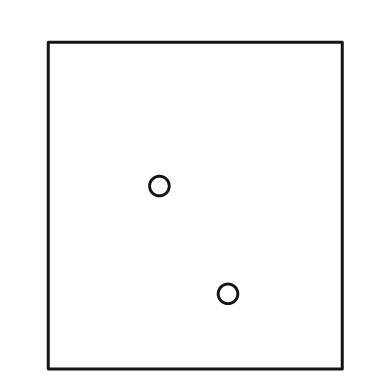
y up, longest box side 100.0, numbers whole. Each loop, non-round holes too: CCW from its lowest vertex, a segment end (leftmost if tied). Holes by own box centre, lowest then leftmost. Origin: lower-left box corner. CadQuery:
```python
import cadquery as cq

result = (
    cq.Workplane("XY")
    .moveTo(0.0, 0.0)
    .lineTo(90.0, 0.0)
    .lineTo(90.0, 100.0)
    .lineTo(0.0, 100.0)
    .close()
    .moveTo(55.0, 23.0)
    .circle(3.0)
    .moveTo(34.0, 56.0)
    .circle(3.0)
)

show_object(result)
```